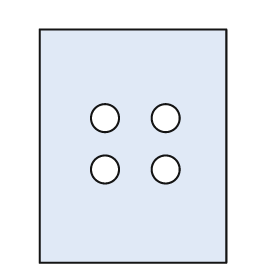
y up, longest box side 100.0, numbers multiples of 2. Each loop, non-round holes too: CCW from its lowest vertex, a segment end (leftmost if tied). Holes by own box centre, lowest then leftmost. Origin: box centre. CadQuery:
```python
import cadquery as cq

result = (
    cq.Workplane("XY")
    .moveTo(-40.0, -50.0)
    .lineTo(40.0, -50.0)
    .lineTo(40.0, 50.0)
    .lineTo(-40.0, 50.0)
    .close()
    .moveTo(-12.0, -10.0)
    .circle(6.0)
    .moveTo(14.0, -10.0)
    .circle(6.0)
    .moveTo(-12.0, 12.0)
    .circle(6.0)
    .moveTo(14.0, 12.0)
    .circle(6.0)
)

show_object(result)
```